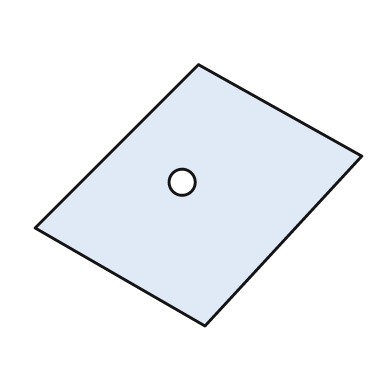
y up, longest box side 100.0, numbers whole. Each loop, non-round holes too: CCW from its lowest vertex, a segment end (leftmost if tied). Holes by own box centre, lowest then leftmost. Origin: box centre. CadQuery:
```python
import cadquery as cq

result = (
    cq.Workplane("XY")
    .moveTo(2.0, -40.0)
    .lineTo(50.0, 12.0)
    .lineTo(0.0, 40.0)
    .lineTo(-50.0, -10.0)
    .close()
    .moveTo(-5.0, 4.0)
    .circle(4.0)
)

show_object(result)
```